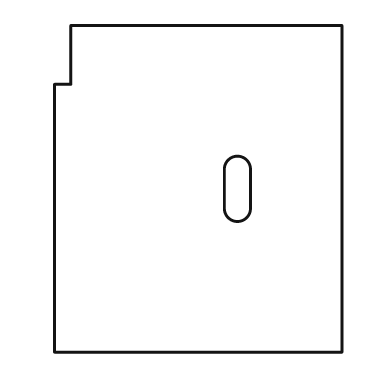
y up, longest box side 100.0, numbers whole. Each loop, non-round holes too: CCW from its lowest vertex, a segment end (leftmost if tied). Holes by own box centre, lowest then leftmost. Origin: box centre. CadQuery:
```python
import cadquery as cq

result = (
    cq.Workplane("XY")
    .moveTo(-44.0, -50.0)
    .lineTo(44.0, -50.0)
    .lineTo(44.0, 50.0)
    .lineTo(-39.0, 50.0)
    .lineTo(-39.0, 32.0)
    .lineTo(-44.0, 32.0)
    .close()
    .moveTo(8.0, -6.0)
    .threePointArc((12.0, -10.0), (16.0, -6.0))
    .lineTo(16.0, 6.0)
    .threePointArc((12.0, 10.0), (8.0, 6.0))
    .close()
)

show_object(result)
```